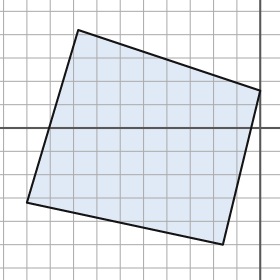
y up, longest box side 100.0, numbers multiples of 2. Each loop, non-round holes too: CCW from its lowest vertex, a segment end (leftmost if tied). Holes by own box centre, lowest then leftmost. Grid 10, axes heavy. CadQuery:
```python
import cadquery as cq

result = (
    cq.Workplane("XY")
    .moveTo(-16.0, -50.0)
    .lineTo(0.0, 16.0)
    .lineTo(-78.0, 42.0)
    .lineTo(-100.0, -32.0)
    .close()
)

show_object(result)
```